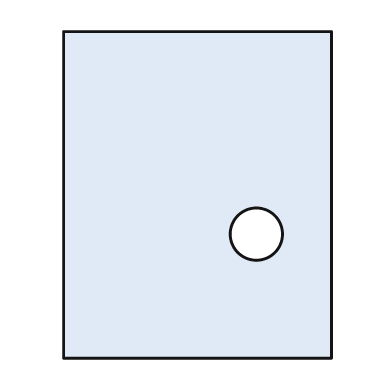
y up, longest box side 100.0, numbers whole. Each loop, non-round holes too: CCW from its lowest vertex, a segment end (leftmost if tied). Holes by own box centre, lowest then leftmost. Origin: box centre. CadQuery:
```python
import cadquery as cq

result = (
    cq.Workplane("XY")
    .moveTo(-41.0, -50.0)
    .lineTo(41.0, -50.0)
    .lineTo(41.0, 50.0)
    .lineTo(-41.0, 50.0)
    .close()
    .moveTo(18.0, -12.0)
    .circle(8.0)
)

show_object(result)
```